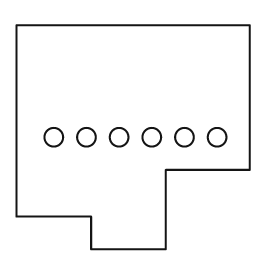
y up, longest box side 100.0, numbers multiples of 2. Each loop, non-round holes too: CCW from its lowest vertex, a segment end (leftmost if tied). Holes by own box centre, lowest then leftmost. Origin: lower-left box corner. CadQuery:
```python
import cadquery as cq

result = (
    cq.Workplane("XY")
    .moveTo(32.0, 0.0)
    .lineTo(64.0, 0.0)
    .lineTo(64.0, 34.0)
    .lineTo(100.0, 34.0)
    .lineTo(100.0, 96.0)
    .lineTo(0.0, 96.0)
    .lineTo(0.0, 14.0)
    .lineTo(32.0, 14.0)
    .close()
    .moveTo(16.0, 48.0)
    .circle(4.0)
    .moveTo(30.0, 48.0)
    .circle(4.0)
    .moveTo(44.0, 48.0)
    .circle(4.0)
    .moveTo(58.0, 48.0)
    .circle(4.0)
    .moveTo(72.0, 48.0)
    .circle(4.0)
    .moveTo(86.0, 48.0)
    .circle(4.0)
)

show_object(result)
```